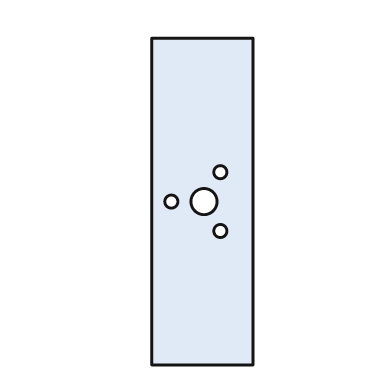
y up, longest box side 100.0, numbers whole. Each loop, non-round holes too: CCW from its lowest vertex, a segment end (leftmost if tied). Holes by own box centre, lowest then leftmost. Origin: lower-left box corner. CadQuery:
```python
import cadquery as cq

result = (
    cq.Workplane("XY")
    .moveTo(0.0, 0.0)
    .lineTo(31.0, 0.0)
    .lineTo(31.0, 100.0)
    .lineTo(0.0, 100.0)
    .close()
    .moveTo(21.0, 41.0)
    .circle(2.0)
    .moveTo(6.0, 50.0)
    .circle(2.0)
    .moveTo(16.0, 50.0)
    .circle(4.0)
    .moveTo(21.0, 59.0)
    .circle(2.0)
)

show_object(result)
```